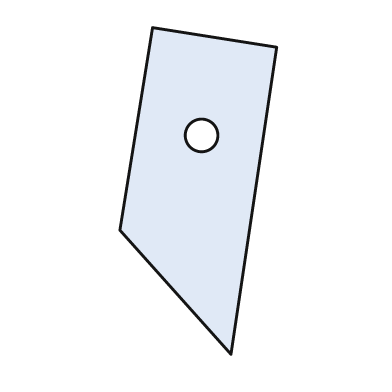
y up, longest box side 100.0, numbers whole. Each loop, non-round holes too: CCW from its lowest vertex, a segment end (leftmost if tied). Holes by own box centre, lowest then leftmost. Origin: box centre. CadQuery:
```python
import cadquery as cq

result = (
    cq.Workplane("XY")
    .moveTo(10.0, -50.0)
    .lineTo(24.0, 44.0)
    .lineTo(-14.0, 50.0)
    .lineTo(-24.0, -12.0)
    .close()
    .moveTo(1.0, 17.0)
    .circle(5.0)
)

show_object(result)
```